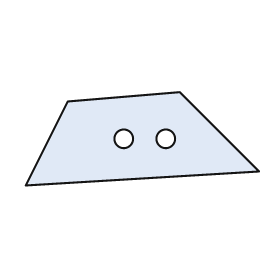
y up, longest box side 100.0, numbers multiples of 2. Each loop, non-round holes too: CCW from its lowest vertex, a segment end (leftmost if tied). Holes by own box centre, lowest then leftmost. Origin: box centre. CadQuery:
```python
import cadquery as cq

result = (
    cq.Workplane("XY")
    .moveTo(-50.0, -20.0)
    .lineTo(50.0, -14.0)
    .lineTo(16.0, 20.0)
    .lineTo(-32.0, 16.0)
    .close()
    .moveTo(-8.0, 0.0)
    .circle(4.0)
    .moveTo(10.0, 0.0)
    .circle(4.0)
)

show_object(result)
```